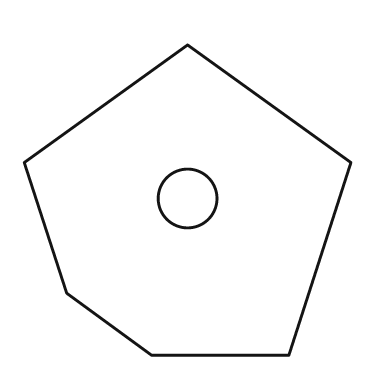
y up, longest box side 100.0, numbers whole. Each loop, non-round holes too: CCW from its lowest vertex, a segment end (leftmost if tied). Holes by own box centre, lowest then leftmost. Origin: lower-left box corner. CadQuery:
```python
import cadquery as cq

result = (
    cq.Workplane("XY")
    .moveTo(39.0, 0.0)
    .lineTo(81.0, 0.0)
    .lineTo(100.0, 59.0)
    .lineTo(50.0, 95.0)
    .lineTo(0.0, 59.0)
    .lineTo(13.0, 19.0)
    .close()
    .moveTo(50.0, 48.0)
    .circle(9.0)
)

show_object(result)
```